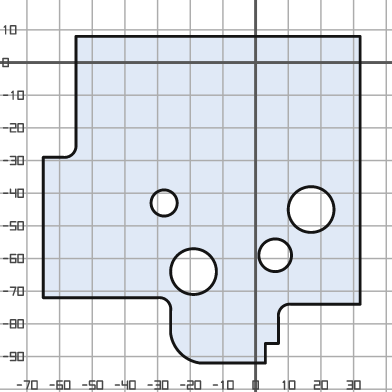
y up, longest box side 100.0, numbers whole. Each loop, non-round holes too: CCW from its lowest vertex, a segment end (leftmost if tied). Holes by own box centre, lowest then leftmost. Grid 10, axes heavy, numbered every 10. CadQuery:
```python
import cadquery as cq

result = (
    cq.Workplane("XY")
    .moveTo(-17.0, -92.0)
    .lineTo(3.0, -92.0)
    .lineTo(3.0, -86.0)
    .lineTo(7.0, -86.0)
    .lineTo(7.0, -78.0)
    .threePointArc((8.0, -75.0), (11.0, -74.0))
    .lineTo(32.0, -74.0)
    .lineTo(32.0, 8.0)
    .lineTo(-55.0, 8.0)
    .lineTo(-55.0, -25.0)
    .threePointArc((-56.0, -28.0), (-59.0, -29.0))
    .lineTo(-65.0, -29.0)
    .lineTo(-65.0, -72.0)
    .lineTo(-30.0, -72.0)
    .threePointArc((-27.0, -73.0), (-26.0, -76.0))
    .lineTo(-26.0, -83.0)
    .threePointArc((-23.0, -89.0), (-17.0, -92.0))
    .close()
    .moveTo(-19.0, -64.0)
    .circle(7.0)
    .moveTo(6.0, -59.0)
    .circle(5.0)
    .moveTo(17.0, -45.0)
    .circle(7.0)
    .moveTo(-28.0, -43.0)
    .circle(4.0)
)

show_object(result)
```